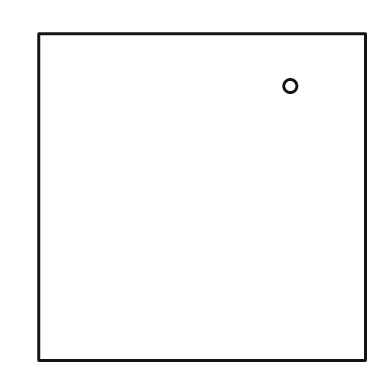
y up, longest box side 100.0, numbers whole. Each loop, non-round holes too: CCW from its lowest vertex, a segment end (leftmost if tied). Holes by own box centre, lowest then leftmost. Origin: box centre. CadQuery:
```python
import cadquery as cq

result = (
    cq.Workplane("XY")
    .moveTo(-50.0, -50.0)
    .lineTo(50.0, -50.0)
    .lineTo(50.0, 50.0)
    .lineTo(-50.0, 50.0)
    .close()
    .moveTo(27.0, 34.0)
    .circle(2.0)
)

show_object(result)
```